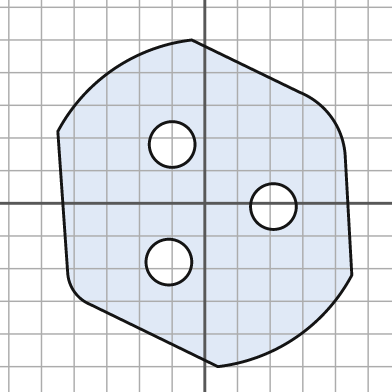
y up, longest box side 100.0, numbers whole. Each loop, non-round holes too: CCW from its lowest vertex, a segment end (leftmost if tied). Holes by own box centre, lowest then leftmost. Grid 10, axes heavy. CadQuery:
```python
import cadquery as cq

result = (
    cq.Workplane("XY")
    .moveTo(4.0, -50.0)
    .threePointArc((28.0, -41.0), (45.0, -22.0))
    .lineTo(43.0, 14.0)
    .threePointArc((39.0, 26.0), (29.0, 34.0))
    .lineTo(-4.0, 50.0)
    .threePointArc((-28.0, 41.0), (-45.0, 22.0))
    .lineTo(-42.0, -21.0)
    .threePointArc((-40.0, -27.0), (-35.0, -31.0))
    .close()
    .moveTo(-11.0, -18.0)
    .circle(7.0)
    .moveTo(21.0, -1.0)
    .circle(7.0)
    .moveTo(-10.0, 18.0)
    .circle(7.0)
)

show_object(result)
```